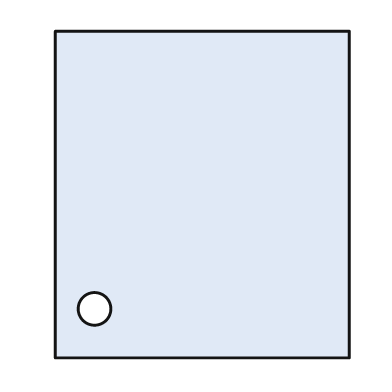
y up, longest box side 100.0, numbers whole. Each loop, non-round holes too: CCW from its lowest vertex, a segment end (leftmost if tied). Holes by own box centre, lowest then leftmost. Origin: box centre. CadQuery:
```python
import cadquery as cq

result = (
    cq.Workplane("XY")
    .moveTo(-45.0, -50.0)
    .lineTo(45.0, -50.0)
    .lineTo(45.0, 50.0)
    .lineTo(-45.0, 50.0)
    .close()
    .moveTo(-33.0, -35.0)
    .circle(5.0)
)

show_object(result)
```